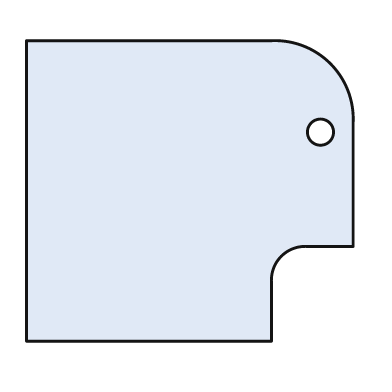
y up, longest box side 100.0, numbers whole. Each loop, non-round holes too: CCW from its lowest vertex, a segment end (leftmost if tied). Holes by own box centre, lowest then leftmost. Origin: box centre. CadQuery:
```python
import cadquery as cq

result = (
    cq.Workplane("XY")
    .moveTo(-50.0, -46.0)
    .lineTo(25.0, -46.0)
    .lineTo(25.0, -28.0)
    .threePointArc((28.0, -20.0), (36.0, -17.0))
    .lineTo(50.0, -17.0)
    .lineTo(50.0, 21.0)
    .threePointArc((43.0, 39.0), (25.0, 46.0))
    .lineTo(-50.0, 46.0)
    .close()
    .moveTo(40.0, 18.0)
    .circle(4.0)
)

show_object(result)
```